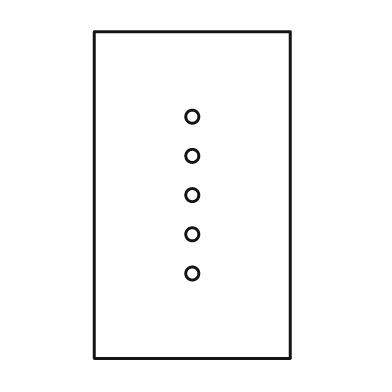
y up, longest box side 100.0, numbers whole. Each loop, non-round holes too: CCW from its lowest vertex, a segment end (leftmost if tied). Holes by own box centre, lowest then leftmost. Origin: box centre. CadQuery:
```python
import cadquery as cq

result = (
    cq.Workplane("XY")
    .moveTo(-30.0, -50.0)
    .lineTo(30.0, -50.0)
    .lineTo(30.0, 50.0)
    .lineTo(-30.0, 50.0)
    .close()
    .moveTo(0.0, -24.0)
    .circle(2.0)
    .moveTo(0.0, -12.0)
    .circle(2.0)
    .moveTo(0.0, 0.0)
    .circle(2.0)
    .moveTo(0.0, 12.0)
    .circle(2.0)
    .moveTo(0.0, 24.0)
    .circle(2.0)
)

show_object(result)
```